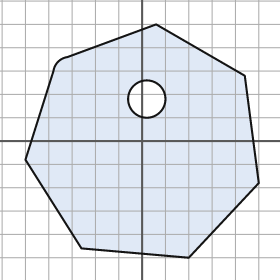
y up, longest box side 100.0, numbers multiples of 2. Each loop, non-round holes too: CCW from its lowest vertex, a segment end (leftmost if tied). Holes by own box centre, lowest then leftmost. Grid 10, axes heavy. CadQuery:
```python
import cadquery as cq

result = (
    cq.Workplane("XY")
    .moveTo(20.0, -50.0)
    .lineTo(50.0, -18.0)
    .lineTo(44.0, 28.0)
    .lineTo(6.0, 50.0)
    .lineTo(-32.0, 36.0)
    .threePointArc((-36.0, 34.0), (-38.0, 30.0))
    .lineTo(-50.0, -8.0)
    .lineTo(-26.0, -46.0)
    .close()
    .moveTo(2.0, 18.0)
    .circle(8.0)
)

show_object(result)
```